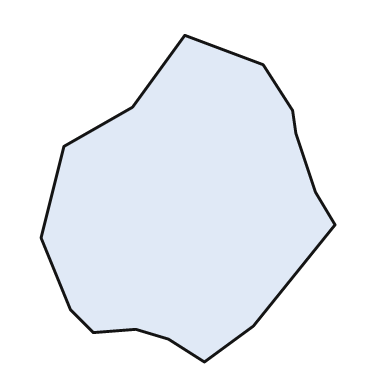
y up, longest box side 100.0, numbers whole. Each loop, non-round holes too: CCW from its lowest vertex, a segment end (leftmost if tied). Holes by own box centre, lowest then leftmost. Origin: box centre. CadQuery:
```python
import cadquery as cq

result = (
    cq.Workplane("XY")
    .moveTo(5.0, -50.0)
    .lineTo(20.0, -39.0)
    .lineTo(45.0, -8.0)
    .lineTo(39.0, 2.0)
    .lineTo(33.0, 20.0)
    .lineTo(32.0, 27.0)
    .lineTo(23.0, 41.0)
    .lineTo(-1.0, 50.0)
    .lineTo(-17.0, 28.0)
    .lineTo(-38.0, 16.0)
    .lineTo(-45.0, -12.0)
    .lineTo(-36.0, -34.0)
    .lineTo(-29.0, -41.0)
    .lineTo(-16.0, -40.0)
    .lineTo(-6.0, -43.0)
    .close()
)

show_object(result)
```